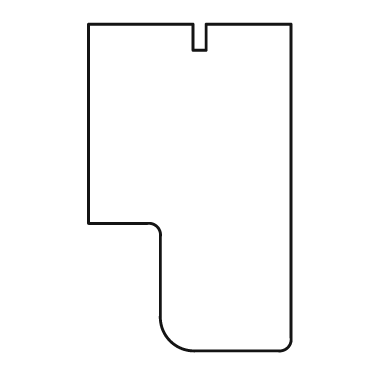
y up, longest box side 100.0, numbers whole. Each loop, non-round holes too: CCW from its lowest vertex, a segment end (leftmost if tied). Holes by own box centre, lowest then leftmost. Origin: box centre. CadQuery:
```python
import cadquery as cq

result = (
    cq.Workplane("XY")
    .moveTo(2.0, -50.0)
    .lineTo(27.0, -50.0)
    .threePointArc((30.0, -49.0), (31.0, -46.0))
    .lineTo(31.0, 50.0)
    .lineTo(5.0, 50.0)
    .lineTo(5.0, 42.0)
    .lineTo(1.0, 42.0)
    .lineTo(1.0, 50.0)
    .lineTo(-31.0, 50.0)
    .lineTo(-31.0, -11.0)
    .lineTo(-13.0, -11.0)
    .threePointArc((-10.0, -12.0), (-9.0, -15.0))
    .lineTo(-9.0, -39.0)
    .threePointArc((-6.0, -47.0), (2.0, -50.0))
    .close()
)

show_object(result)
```